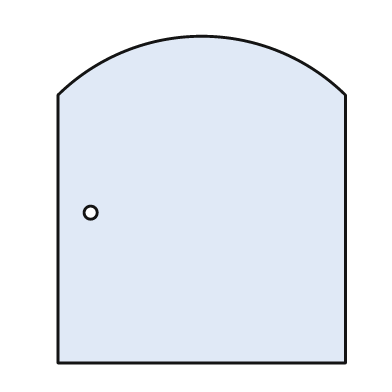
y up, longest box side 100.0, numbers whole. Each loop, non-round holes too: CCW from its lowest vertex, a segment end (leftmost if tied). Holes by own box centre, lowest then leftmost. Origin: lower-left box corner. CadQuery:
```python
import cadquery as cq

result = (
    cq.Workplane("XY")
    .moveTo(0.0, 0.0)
    .lineTo(88.0, 0.0)
    .lineTo(88.0, 82.0)
    .threePointArc((44.0, 100.0), (0.0, 82.0))
    .close()
    .moveTo(10.0, 46.0)
    .circle(2.0)
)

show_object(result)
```